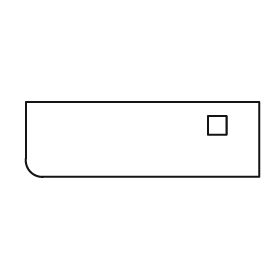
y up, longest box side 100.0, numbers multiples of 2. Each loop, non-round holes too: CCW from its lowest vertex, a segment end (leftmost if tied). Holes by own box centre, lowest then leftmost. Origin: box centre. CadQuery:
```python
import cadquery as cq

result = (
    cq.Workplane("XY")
    .moveTo(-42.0, -16.0)
    .lineTo(50.0, -16.0)
    .lineTo(50.0, 16.0)
    .lineTo(-50.0, 16.0)
    .lineTo(-50.0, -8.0)
    .threePointArc((-48.0, -14.0), (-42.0, -16.0))
    .close()
    .moveTo(28.0, 2.0)
    .lineTo(36.0, 2.0)
    .lineTo(36.0, 10.0)
    .lineTo(28.0, 10.0)
    .close()
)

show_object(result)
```